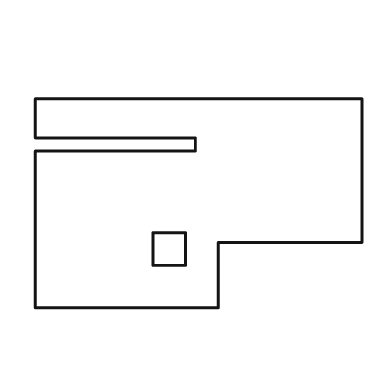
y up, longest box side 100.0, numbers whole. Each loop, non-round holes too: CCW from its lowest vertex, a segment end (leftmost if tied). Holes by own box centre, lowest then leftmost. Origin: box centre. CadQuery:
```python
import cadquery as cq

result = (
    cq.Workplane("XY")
    .moveTo(-50.0, -32.0)
    .lineTo(6.0, -32.0)
    .lineTo(6.0, -12.0)
    .lineTo(50.0, -12.0)
    .lineTo(50.0, 32.0)
    .lineTo(-50.0, 32.0)
    .lineTo(-50.0, 20.0)
    .lineTo(-1.0, 20.0)
    .lineTo(-1.0, 16.0)
    .lineTo(-50.0, 16.0)
    .close()
    .moveTo(-14.0, -19.0)
    .lineTo(-4.0, -19.0)
    .lineTo(-4.0, -9.0)
    .lineTo(-14.0, -9.0)
    .close()
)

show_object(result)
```